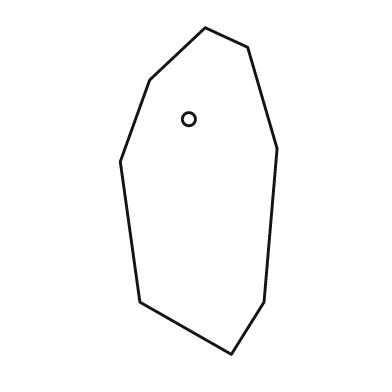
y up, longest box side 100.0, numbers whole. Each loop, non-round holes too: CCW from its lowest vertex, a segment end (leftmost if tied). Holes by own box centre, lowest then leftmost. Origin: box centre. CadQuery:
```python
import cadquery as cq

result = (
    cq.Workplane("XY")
    .moveTo(10.0, -50.0)
    .lineTo(20.0, -34.0)
    .lineTo(24.0, 13.0)
    .lineTo(15.0, 44.0)
    .lineTo(2.0, 50.0)
    .lineTo(-15.0, 34.0)
    .lineTo(-24.0, 9.0)
    .lineTo(-18.0, -34.0)
    .close()
    .moveTo(-3.0, 22.0)
    .circle(2.0)
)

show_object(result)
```